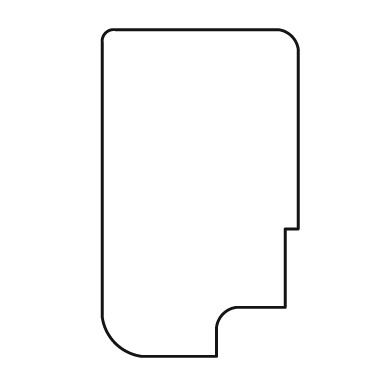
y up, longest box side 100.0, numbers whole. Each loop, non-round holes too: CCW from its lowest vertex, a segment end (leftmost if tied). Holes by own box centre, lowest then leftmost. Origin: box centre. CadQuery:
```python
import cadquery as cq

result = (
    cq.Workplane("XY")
    .moveTo(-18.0, -50.0)
    .lineTo(5.0, -50.0)
    .lineTo(5.0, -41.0)
    .threePointArc((7.0, -37.0), (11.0, -35.0))
    .lineTo(26.0, -35.0)
    .lineTo(26.0, -11.0)
    .lineTo(30.0, -11.0)
    .lineTo(30.0, 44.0)
    .threePointArc((28.0, 48.0), (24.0, 50.0))
    .lineTo(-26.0, 50.0)
    .threePointArc((-29.0, 49.0), (-30.0, 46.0))
    .lineTo(-30.0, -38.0)
    .threePointArc((-26.0, -46.0), (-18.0, -50.0))
    .close()
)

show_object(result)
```